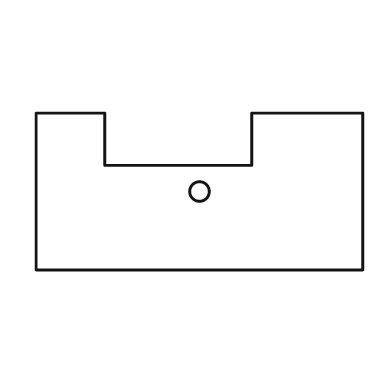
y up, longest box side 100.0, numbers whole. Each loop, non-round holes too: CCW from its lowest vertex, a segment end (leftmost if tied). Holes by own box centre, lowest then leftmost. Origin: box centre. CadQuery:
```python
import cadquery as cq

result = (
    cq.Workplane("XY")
    .moveTo(-50.0, -24.0)
    .lineTo(50.0, -24.0)
    .lineTo(50.0, 24.0)
    .lineTo(16.0, 24.0)
    .lineTo(16.0, 8.0)
    .lineTo(-29.0, 8.0)
    .lineTo(-29.0, 24.0)
    .lineTo(-50.0, 24.0)
    .close()
    .moveTo(0.0, 0.0)
    .circle(3.0)
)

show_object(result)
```